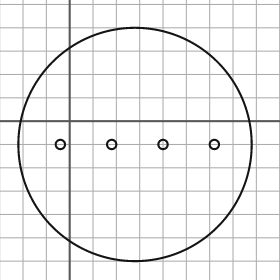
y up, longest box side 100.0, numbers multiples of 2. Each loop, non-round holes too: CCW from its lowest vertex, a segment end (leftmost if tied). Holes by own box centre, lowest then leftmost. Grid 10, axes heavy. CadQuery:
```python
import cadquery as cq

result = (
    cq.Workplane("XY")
    .moveTo(28.0, -10.0)
    .circle(50.0)
    .moveTo(-4.0, -10.0)
    .circle(2.0)
    .moveTo(18.0, -10.0)
    .circle(2.0)
    .moveTo(40.0, -10.0)
    .circle(2.0)
    .moveTo(62.0, -10.0)
    .circle(2.0)
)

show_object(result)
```